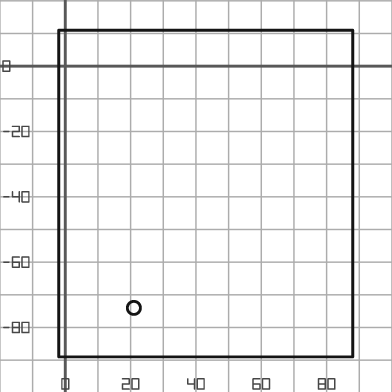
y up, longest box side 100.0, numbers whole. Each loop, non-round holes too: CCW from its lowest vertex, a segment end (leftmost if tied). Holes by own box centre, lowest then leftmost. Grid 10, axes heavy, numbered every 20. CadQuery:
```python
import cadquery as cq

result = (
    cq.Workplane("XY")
    .moveTo(-2.0, -89.0)
    .lineTo(88.0, -89.0)
    .lineTo(88.0, 11.0)
    .lineTo(-2.0, 11.0)
    .close()
    .moveTo(21.0, -74.0)
    .circle(2.0)
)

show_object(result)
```